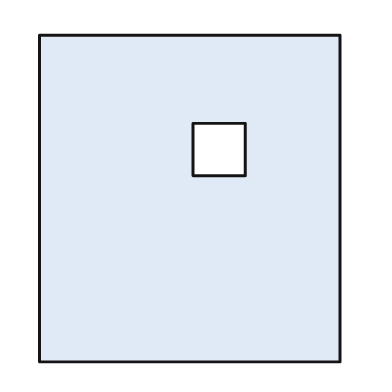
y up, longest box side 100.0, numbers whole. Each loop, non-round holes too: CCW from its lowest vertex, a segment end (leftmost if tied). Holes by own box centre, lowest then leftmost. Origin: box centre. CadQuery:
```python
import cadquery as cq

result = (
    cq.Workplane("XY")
    .moveTo(-46.0, -50.0)
    .lineTo(46.0, -50.0)
    .lineTo(46.0, 50.0)
    .lineTo(-46.0, 50.0)
    .close()
    .moveTo(1.0, 7.0)
    .lineTo(17.0, 7.0)
    .lineTo(17.0, 23.0)
    .lineTo(1.0, 23.0)
    .close()
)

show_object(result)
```